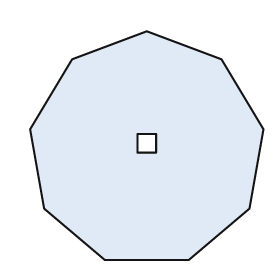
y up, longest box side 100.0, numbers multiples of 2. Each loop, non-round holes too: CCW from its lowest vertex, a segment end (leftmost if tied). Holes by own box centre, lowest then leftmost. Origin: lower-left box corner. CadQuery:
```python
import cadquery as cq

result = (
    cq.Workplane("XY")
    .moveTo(32.0, 0.0)
    .lineTo(68.0, 0.0)
    .lineTo(94.0, 22.0)
    .lineTo(100.0, 56.0)
    .lineTo(82.0, 86.0)
    .lineTo(50.0, 98.0)
    .lineTo(18.0, 86.0)
    .lineTo(0.0, 56.0)
    .lineTo(6.0, 22.0)
    .close()
    .moveTo(46.0, 46.0)
    .lineTo(54.0, 46.0)
    .lineTo(54.0, 54.0)
    .lineTo(46.0, 54.0)
    .close()
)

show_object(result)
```